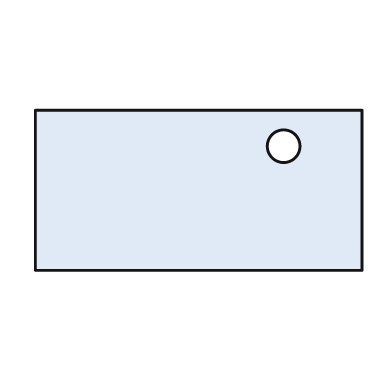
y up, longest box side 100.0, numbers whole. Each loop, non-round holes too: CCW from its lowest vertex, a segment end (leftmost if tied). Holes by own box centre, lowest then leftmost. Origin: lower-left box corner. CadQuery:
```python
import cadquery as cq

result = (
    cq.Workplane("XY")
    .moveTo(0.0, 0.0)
    .lineTo(100.0, 0.0)
    .lineTo(100.0, 49.0)
    .lineTo(0.0, 49.0)
    .close()
    .moveTo(76.0, 38.0)
    .circle(5.0)
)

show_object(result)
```